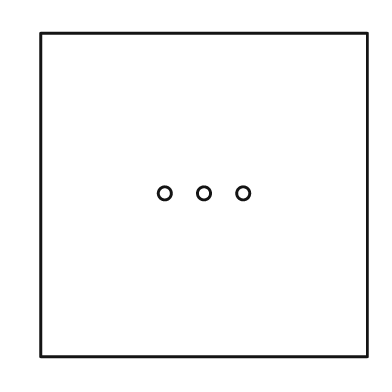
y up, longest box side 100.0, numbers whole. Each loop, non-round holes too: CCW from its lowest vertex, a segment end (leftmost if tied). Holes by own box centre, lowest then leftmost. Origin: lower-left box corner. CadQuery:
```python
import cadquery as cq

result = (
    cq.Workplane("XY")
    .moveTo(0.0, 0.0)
    .lineTo(100.0, 0.0)
    .lineTo(100.0, 99.0)
    .lineTo(0.0, 99.0)
    .close()
    .moveTo(38.0, 50.0)
    .circle(2.0)
    .moveTo(50.0, 50.0)
    .circle(2.0)
    .moveTo(62.0, 50.0)
    .circle(2.0)
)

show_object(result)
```